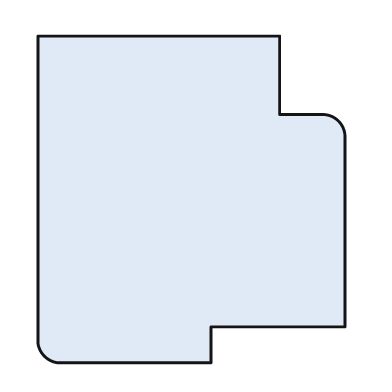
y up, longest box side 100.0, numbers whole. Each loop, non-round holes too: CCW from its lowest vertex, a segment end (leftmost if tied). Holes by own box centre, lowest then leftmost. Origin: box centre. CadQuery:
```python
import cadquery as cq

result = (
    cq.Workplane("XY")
    .moveTo(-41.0, -50.0)
    .lineTo(6.0, -50.0)
    .lineTo(6.0, -39.0)
    .lineTo(47.0, -39.0)
    .lineTo(47.0, 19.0)
    .threePointArc((45.0, 24.0), (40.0, 26.0))
    .lineTo(27.0, 26.0)
    .lineTo(27.0, 50.0)
    .lineTo(-47.0, 50.0)
    .lineTo(-47.0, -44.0)
    .threePointArc((-45.0, -48.0), (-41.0, -50.0))
    .close()
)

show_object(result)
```